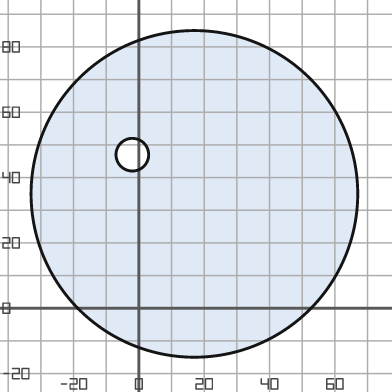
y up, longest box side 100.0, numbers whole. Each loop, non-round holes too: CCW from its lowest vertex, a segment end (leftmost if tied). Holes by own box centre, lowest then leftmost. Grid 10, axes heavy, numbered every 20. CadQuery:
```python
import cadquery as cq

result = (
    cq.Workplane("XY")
    .moveTo(17.0, 35.0)
    .circle(50.0)
    .moveTo(-2.0, 47.0)
    .circle(5.0)
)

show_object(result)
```